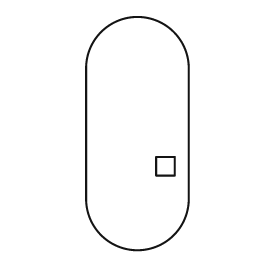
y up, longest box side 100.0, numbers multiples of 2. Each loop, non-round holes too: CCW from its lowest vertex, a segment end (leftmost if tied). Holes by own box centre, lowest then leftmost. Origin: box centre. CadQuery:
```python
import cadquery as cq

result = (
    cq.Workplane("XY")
    .moveTo(-22.0, -28.0)
    .threePointArc((0.0, -50.0), (22.0, -28.0))
    .lineTo(22.0, 28.0)
    .threePointArc((0.0, 50.0), (-22.0, 28.0))
    .close()
    .moveTo(8.0, -18.0)
    .lineTo(16.0, -18.0)
    .lineTo(16.0, -10.0)
    .lineTo(8.0, -10.0)
    .close()
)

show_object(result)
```